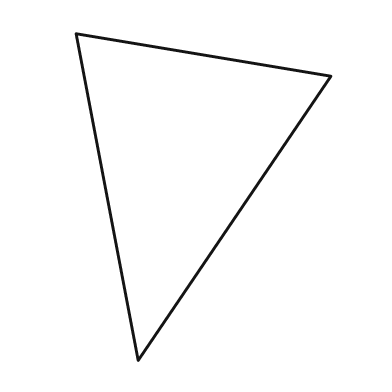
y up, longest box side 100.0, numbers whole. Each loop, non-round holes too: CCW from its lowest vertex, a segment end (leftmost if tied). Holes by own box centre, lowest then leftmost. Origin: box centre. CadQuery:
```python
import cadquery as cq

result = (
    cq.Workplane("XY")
    .moveTo(-20.0, -50.0)
    .lineTo(39.0, 37.0)
    .lineTo(-39.0, 50.0)
    .close()
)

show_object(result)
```